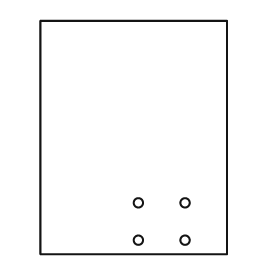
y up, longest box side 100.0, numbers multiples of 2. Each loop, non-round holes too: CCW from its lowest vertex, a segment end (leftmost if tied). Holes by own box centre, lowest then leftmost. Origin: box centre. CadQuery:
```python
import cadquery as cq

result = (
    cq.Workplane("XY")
    .moveTo(-40.0, -50.0)
    .lineTo(40.0, -50.0)
    .lineTo(40.0, 50.0)
    .lineTo(-40.0, 50.0)
    .close()
    .moveTo(2.0, -44.0)
    .circle(2.0)
    .moveTo(22.0, -44.0)
    .circle(2.0)
    .moveTo(2.0, -28.0)
    .circle(2.0)
    .moveTo(22.0, -28.0)
    .circle(2.0)
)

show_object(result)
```